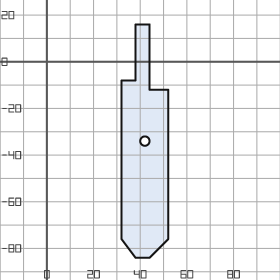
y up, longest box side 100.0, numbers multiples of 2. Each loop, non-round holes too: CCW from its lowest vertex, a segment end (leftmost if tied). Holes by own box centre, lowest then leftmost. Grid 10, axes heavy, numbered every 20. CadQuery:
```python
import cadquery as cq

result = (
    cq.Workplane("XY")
    .moveTo(38.0, -84.0)
    .lineTo(44.0, -84.0)
    .lineTo(52.0, -76.0)
    .lineTo(52.0, -12.0)
    .lineTo(44.0, -12.0)
    .lineTo(44.0, 16.0)
    .lineTo(38.0, 16.0)
    .lineTo(38.0, -8.0)
    .lineTo(32.0, -8.0)
    .lineTo(32.0, -76.0)
    .close()
    .moveTo(42.0, -34.0)
    .circle(2.0)
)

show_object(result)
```